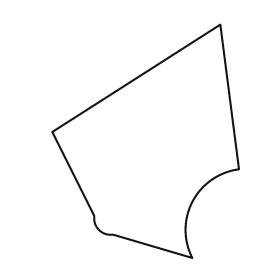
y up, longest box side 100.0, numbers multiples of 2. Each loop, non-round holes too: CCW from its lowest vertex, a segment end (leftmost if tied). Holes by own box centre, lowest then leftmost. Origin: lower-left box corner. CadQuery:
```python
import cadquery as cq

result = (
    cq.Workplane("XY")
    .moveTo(60.0, 0.0)
    .threePointArc((60.0, 24.0), (80.0, 38.0))
    .lineTo(72.0, 100.0)
    .lineTo(0.0, 54.0)
    .lineTo(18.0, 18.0)
    .threePointArc((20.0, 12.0), (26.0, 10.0))
    .close()
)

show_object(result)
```